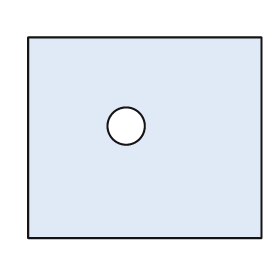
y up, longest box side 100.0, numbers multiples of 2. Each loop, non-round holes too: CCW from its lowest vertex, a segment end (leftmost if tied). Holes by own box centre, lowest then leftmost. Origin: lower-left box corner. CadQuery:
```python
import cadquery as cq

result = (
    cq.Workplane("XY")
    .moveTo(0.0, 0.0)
    .lineTo(100.0, 0.0)
    .lineTo(100.0, 86.0)
    .lineTo(0.0, 86.0)
    .close()
    .moveTo(42.0, 48.0)
    .circle(8.0)
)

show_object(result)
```